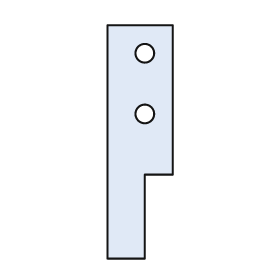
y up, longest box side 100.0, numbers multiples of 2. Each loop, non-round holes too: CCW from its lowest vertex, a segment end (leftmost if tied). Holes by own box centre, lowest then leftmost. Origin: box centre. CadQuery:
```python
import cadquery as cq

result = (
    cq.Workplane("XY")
    .moveTo(-14.0, -50.0)
    .lineTo(2.0, -50.0)
    .lineTo(2.0, -14.0)
    .lineTo(14.0, -14.0)
    .lineTo(14.0, 50.0)
    .lineTo(-14.0, 50.0)
    .close()
    .moveTo(2.0, 12.0)
    .circle(4.0)
    .moveTo(2.0, 38.0)
    .circle(4.0)
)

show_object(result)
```